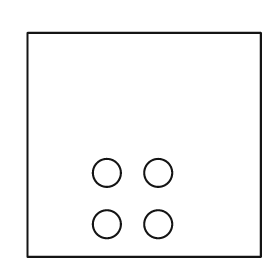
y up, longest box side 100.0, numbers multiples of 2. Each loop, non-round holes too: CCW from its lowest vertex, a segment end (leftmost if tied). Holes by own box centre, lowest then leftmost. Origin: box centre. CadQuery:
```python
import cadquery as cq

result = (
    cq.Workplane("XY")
    .moveTo(-50.0, -48.0)
    .lineTo(50.0, -48.0)
    .lineTo(50.0, 48.0)
    .lineTo(-50.0, 48.0)
    .close()
    .moveTo(-16.0, -34.0)
    .circle(6.0)
    .moveTo(6.0, -34.0)
    .circle(6.0)
    .moveTo(-16.0, -12.0)
    .circle(6.0)
    .moveTo(6.0, -12.0)
    .circle(6.0)
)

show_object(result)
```